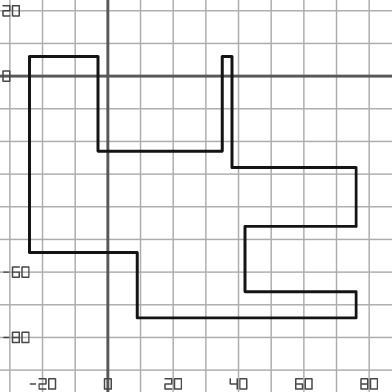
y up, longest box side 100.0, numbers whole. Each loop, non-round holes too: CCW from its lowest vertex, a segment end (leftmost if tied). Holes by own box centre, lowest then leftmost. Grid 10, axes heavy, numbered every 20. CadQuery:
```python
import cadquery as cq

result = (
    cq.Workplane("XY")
    .moveTo(9.0, -74.0)
    .lineTo(76.0, -74.0)
    .lineTo(76.0, -66.0)
    .lineTo(42.0, -66.0)
    .lineTo(42.0, -46.0)
    .lineTo(76.0, -46.0)
    .lineTo(76.0, -28.0)
    .lineTo(38.0, -28.0)
    .lineTo(38.0, 6.0)
    .lineTo(35.0, 6.0)
    .lineTo(35.0, -23.0)
    .lineTo(-3.0, -23.0)
    .lineTo(-3.0, 6.0)
    .lineTo(-24.0, 6.0)
    .lineTo(-24.0, -54.0)
    .lineTo(9.0, -54.0)
    .close()
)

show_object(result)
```